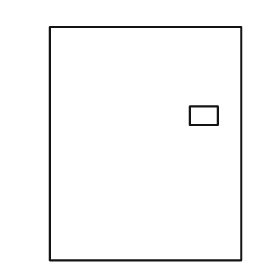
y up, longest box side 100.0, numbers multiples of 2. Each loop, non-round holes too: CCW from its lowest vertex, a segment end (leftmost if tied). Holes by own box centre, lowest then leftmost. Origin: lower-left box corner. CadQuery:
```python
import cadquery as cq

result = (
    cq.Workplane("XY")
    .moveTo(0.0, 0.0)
    .lineTo(82.0, 0.0)
    .lineTo(82.0, 100.0)
    .lineTo(0.0, 100.0)
    .close()
    .moveTo(60.0, 58.0)
    .lineTo(72.0, 58.0)
    .lineTo(72.0, 66.0)
    .lineTo(60.0, 66.0)
    .close()
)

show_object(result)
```